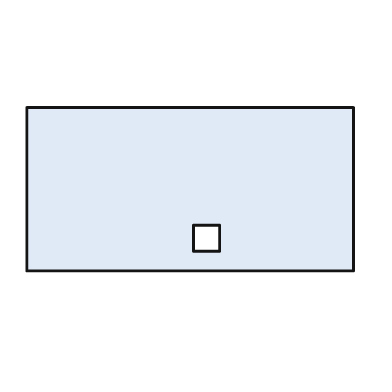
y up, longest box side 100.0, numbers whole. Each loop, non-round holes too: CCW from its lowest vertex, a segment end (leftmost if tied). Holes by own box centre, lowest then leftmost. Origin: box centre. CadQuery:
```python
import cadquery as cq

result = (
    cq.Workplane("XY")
    .moveTo(-50.0, -25.0)
    .lineTo(50.0, -25.0)
    .lineTo(50.0, 25.0)
    .lineTo(-50.0, 25.0)
    .close()
    .moveTo(1.0, -19.0)
    .lineTo(9.0, -19.0)
    .lineTo(9.0, -11.0)
    .lineTo(1.0, -11.0)
    .close()
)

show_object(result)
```